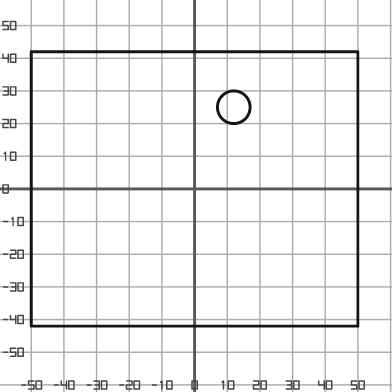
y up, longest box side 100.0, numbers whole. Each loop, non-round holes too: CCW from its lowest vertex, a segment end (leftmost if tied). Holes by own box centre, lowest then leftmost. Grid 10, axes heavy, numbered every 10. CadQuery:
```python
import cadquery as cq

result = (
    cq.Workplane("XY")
    .moveTo(-50.0, -42.0)
    .lineTo(50.0, -42.0)
    .lineTo(50.0, 42.0)
    .lineTo(-50.0, 42.0)
    .close()
    .moveTo(12.0, 25.0)
    .circle(5.0)
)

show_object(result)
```